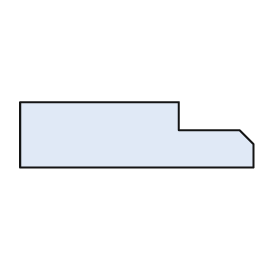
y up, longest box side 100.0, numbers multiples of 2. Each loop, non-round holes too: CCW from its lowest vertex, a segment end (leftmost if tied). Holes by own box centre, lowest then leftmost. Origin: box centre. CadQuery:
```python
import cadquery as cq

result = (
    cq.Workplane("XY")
    .moveTo(-50.0, -14.0)
    .lineTo(50.0, -14.0)
    .lineTo(50.0, -4.0)
    .lineTo(44.0, 2.0)
    .lineTo(18.0, 2.0)
    .lineTo(18.0, 14.0)
    .lineTo(-50.0, 14.0)
    .close()
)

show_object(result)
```